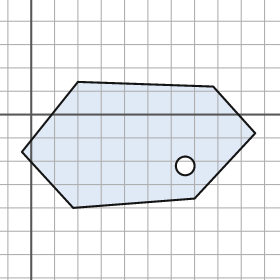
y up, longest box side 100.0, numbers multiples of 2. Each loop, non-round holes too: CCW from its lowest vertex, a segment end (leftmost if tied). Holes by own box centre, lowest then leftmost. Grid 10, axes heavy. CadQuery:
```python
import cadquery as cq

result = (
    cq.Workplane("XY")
    .moveTo(18.0, -40.0)
    .lineTo(70.0, -36.0)
    .lineTo(96.0, -8.0)
    .lineTo(78.0, 12.0)
    .lineTo(20.0, 14.0)
    .lineTo(-4.0, -16.0)
    .close()
    .moveTo(66.0, -22.0)
    .circle(4.0)
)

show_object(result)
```